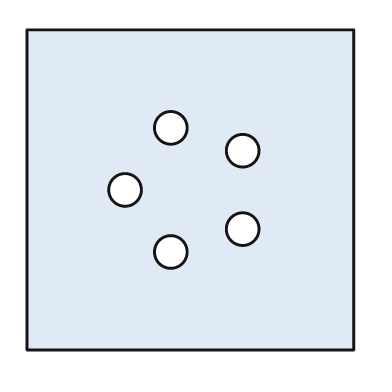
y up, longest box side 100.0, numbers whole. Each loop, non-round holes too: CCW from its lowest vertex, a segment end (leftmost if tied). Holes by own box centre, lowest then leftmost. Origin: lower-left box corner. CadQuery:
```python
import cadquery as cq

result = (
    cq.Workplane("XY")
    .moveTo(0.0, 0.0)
    .lineTo(100.0, 0.0)
    .lineTo(100.0, 98.0)
    .lineTo(0.0, 98.0)
    .close()
    .moveTo(44.0, 30.0)
    .circle(5.0)
    .moveTo(66.0, 37.0)
    .circle(5.0)
    .moveTo(30.0, 49.0)
    .circle(5.0)
    .moveTo(66.0, 61.0)
    .circle(5.0)
    .moveTo(44.0, 68.0)
    .circle(5.0)
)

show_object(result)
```